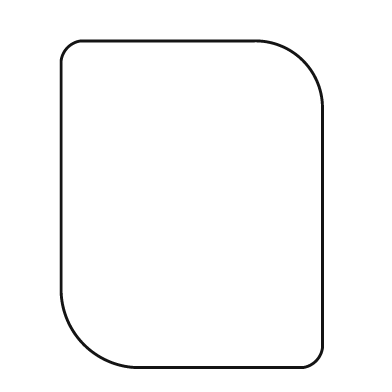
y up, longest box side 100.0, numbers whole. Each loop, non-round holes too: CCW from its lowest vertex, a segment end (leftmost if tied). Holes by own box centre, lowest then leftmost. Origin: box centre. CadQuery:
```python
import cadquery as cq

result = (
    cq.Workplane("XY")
    .moveTo(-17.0, -50.0)
    .lineTo(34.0, -50.0)
    .threePointArc((38.0, -48.0), (40.0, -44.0))
    .lineTo(40.0, 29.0)
    .threePointArc((34.0, 44.0), (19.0, 50.0))
    .lineTo(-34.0, 50.0)
    .threePointArc((-38.0, 48.0), (-40.0, 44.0))
    .lineTo(-40.0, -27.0)
    .threePointArc((-33.0, -43.0), (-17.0, -50.0))
    .close()
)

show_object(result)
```